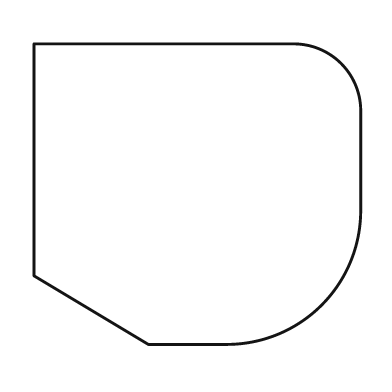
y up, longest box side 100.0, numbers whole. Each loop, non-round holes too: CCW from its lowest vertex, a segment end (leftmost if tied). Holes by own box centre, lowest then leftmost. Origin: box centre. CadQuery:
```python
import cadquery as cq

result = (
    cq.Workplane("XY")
    .moveTo(-15.0, -46.0)
    .lineTo(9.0, -46.0)
    .threePointArc((38.0, -34.0), (50.0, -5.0))
    .lineTo(50.0, 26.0)
    .threePointArc((44.0, 40.0), (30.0, 46.0))
    .lineTo(-50.0, 46.0)
    .lineTo(-50.0, -25.0)
    .close()
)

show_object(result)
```